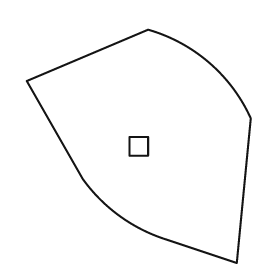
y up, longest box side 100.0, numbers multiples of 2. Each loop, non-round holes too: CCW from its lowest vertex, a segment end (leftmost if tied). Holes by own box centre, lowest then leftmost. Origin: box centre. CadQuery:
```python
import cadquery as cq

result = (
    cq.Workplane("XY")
    .moveTo(42.0, -50.0)
    .lineTo(48.0, 12.0)
    .threePointArc((30.0, 36.0), (4.0, 50.0))
    .lineTo(-48.0, 28.0)
    .lineTo(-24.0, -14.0)
    .threePointArc((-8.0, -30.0), (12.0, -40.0))
    .close()
    .moveTo(-4.0, -4.0)
    .lineTo(4.0, -4.0)
    .lineTo(4.0, 4.0)
    .lineTo(-4.0, 4.0)
    .close()
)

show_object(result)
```